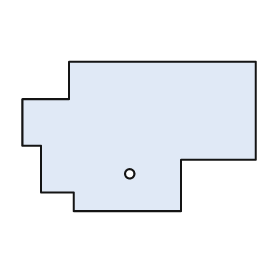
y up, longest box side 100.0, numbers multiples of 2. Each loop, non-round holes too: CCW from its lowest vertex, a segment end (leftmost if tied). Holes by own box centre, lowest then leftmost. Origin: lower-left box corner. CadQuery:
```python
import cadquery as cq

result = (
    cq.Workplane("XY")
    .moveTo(22.0, 0.0)
    .lineTo(68.0, 0.0)
    .lineTo(68.0, 22.0)
    .lineTo(100.0, 22.0)
    .lineTo(100.0, 64.0)
    .lineTo(20.0, 64.0)
    .lineTo(20.0, 48.0)
    .lineTo(0.0, 48.0)
    .lineTo(0.0, 28.0)
    .lineTo(8.0, 28.0)
    .lineTo(8.0, 8.0)
    .lineTo(22.0, 8.0)
    .close()
    .moveTo(46.0, 16.0)
    .circle(2.0)
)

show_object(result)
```